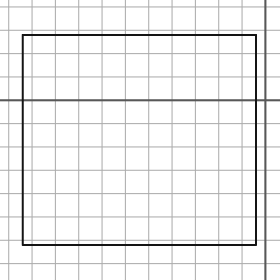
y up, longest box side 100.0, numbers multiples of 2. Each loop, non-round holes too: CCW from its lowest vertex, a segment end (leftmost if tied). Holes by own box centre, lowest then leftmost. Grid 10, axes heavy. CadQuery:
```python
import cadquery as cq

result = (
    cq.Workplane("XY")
    .moveTo(-104.0, -62.0)
    .lineTo(-4.0, -62.0)
    .lineTo(-4.0, 28.0)
    .lineTo(-104.0, 28.0)
    .close()
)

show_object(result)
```